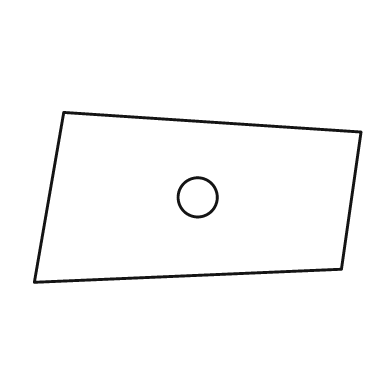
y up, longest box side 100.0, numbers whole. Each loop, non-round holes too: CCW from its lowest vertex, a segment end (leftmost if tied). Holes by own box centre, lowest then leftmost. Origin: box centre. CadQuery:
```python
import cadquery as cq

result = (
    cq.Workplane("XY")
    .moveTo(-50.0, -26.0)
    .lineTo(44.0, -22.0)
    .lineTo(50.0, 20.0)
    .lineTo(-41.0, 26.0)
    .close()
    .moveTo(0.0, 0.0)
    .circle(6.0)
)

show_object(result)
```